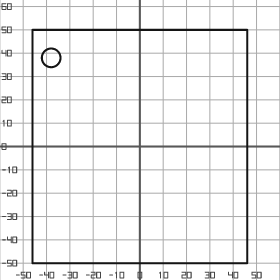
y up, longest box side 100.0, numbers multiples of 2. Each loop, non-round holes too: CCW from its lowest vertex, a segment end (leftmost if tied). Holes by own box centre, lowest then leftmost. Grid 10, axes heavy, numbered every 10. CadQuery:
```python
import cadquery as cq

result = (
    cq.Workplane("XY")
    .moveTo(-46.0, -50.0)
    .lineTo(46.0, -50.0)
    .lineTo(46.0, 50.0)
    .lineTo(-46.0, 50.0)
    .close()
    .moveTo(-38.0, 38.0)
    .circle(4.0)
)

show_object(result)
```